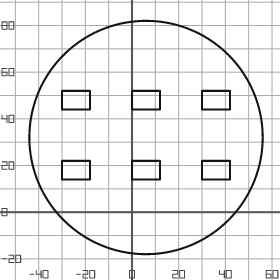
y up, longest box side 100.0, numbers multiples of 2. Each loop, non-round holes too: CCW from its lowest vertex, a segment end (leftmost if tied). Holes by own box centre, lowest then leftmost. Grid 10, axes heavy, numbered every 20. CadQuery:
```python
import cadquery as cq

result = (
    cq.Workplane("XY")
    .moveTo(6.0, 32.0)
    .circle(50.0)
    .moveTo(-30.0, 14.0)
    .lineTo(-18.0, 14.0)
    .lineTo(-18.0, 22.0)
    .lineTo(-30.0, 22.0)
    .close()
    .moveTo(0.0, 14.0)
    .lineTo(12.0, 14.0)
    .lineTo(12.0, 22.0)
    .lineTo(0.0, 22.0)
    .close()
    .moveTo(30.0, 14.0)
    .lineTo(42.0, 14.0)
    .lineTo(42.0, 22.0)
    .lineTo(30.0, 22.0)
    .close()
    .moveTo(-30.0, 44.0)
    .lineTo(-18.0, 44.0)
    .lineTo(-18.0, 52.0)
    .lineTo(-30.0, 52.0)
    .close()
    .moveTo(0.0, 44.0)
    .lineTo(12.0, 44.0)
    .lineTo(12.0, 52.0)
    .lineTo(0.0, 52.0)
    .close()
    .moveTo(30.0, 44.0)
    .lineTo(42.0, 44.0)
    .lineTo(42.0, 52.0)
    .lineTo(30.0, 52.0)
    .close()
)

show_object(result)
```